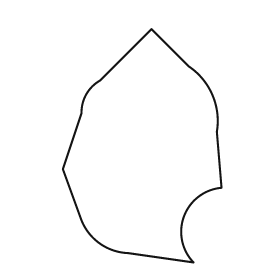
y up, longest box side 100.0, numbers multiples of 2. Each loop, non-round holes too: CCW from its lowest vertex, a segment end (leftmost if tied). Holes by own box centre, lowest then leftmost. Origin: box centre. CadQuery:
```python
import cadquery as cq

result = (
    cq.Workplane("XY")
    .moveTo(22.0, -50.0)
    .threePointArc((18.0, -30.0), (34.0, -18.0))
    .lineTo(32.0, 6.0)
    .threePointArc((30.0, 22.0), (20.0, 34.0))
    .lineTo(4.0, 50.0)
    .lineTo(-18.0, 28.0)
    .threePointArc((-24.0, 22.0), (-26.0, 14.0))
    .lineTo(-34.0, -10.0)
    .lineTo(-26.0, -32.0)
    .threePointArc((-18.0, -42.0), (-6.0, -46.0))
    .close()
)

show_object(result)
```